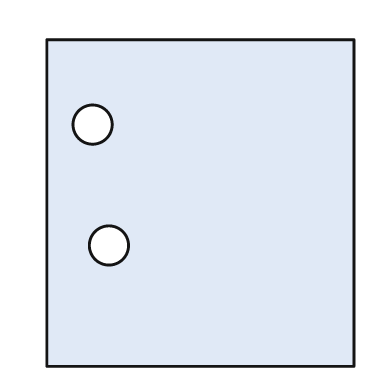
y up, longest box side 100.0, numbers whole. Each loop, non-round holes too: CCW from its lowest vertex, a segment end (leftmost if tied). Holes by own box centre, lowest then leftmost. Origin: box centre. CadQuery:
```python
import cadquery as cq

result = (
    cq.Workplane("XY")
    .moveTo(-47.0, -50.0)
    .lineTo(47.0, -50.0)
    .lineTo(47.0, 50.0)
    .lineTo(-47.0, 50.0)
    .close()
    .moveTo(-28.0, -13.0)
    .circle(6.0)
    .moveTo(-33.0, 24.0)
    .circle(6.0)
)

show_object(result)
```